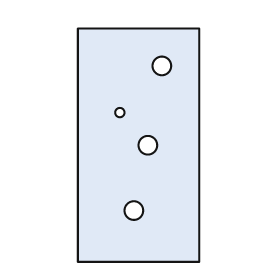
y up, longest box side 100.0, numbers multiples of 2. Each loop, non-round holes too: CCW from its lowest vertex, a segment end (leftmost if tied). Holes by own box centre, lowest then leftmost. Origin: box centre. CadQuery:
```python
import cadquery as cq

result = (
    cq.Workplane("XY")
    .moveTo(-26.0, -50.0)
    .lineTo(26.0, -50.0)
    .lineTo(26.0, 50.0)
    .lineTo(-26.0, 50.0)
    .close()
    .moveTo(-2.0, -28.0)
    .circle(4.0)
    .moveTo(4.0, 0.0)
    .circle(4.0)
    .moveTo(-8.0, 14.0)
    .circle(2.0)
    .moveTo(10.0, 34.0)
    .circle(4.0)
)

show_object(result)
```